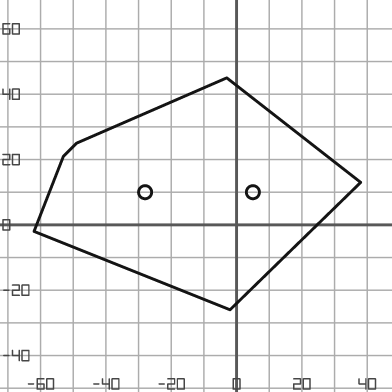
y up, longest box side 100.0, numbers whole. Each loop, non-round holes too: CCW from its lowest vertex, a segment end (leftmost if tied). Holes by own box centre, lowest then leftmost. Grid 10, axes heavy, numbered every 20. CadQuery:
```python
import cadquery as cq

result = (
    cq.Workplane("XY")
    .moveTo(-2.0, -26.0)
    .lineTo(38.0, 13.0)
    .lineTo(-3.0, 45.0)
    .lineTo(-49.0, 25.0)
    .lineTo(-53.0, 21.0)
    .lineTo(-62.0, -2.0)
    .close()
    .moveTo(-28.0, 10.0)
    .circle(2.0)
    .moveTo(5.0, 10.0)
    .circle(2.0)
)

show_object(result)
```